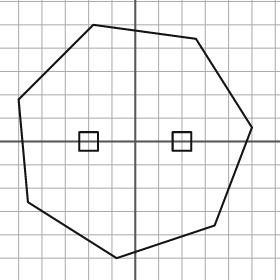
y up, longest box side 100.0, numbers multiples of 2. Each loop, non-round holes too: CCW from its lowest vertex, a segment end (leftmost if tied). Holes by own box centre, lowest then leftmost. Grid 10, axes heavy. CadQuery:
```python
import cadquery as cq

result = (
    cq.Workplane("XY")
    .moveTo(-8.0, -50.0)
    .lineTo(34.0, -36.0)
    .lineTo(50.0, 6.0)
    .lineTo(26.0, 44.0)
    .lineTo(-18.0, 50.0)
    .lineTo(-50.0, 18.0)
    .lineTo(-46.0, -26.0)
    .close()
    .moveTo(-24.0, -4.0)
    .lineTo(-16.0, -4.0)
    .lineTo(-16.0, 4.0)
    .lineTo(-24.0, 4.0)
    .close()
    .moveTo(16.0, -4.0)
    .lineTo(24.0, -4.0)
    .lineTo(24.0, 4.0)
    .lineTo(16.0, 4.0)
    .close()
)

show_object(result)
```